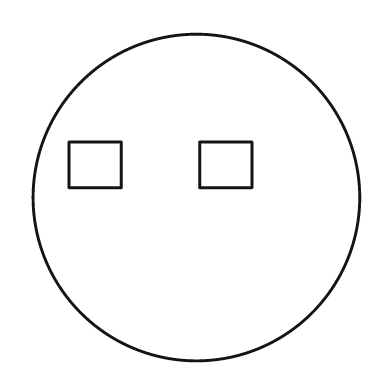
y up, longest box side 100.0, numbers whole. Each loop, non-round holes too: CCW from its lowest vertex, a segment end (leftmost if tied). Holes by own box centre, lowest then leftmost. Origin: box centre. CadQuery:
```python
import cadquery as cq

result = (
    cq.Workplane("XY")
    .moveTo(0.0, 0.0)
    .circle(50.0)
    .moveTo(-39.0, 3.0)
    .lineTo(-23.0, 3.0)
    .lineTo(-23.0, 17.0)
    .lineTo(-39.0, 17.0)
    .close()
    .moveTo(1.0, 3.0)
    .lineTo(17.0, 3.0)
    .lineTo(17.0, 17.0)
    .lineTo(1.0, 17.0)
    .close()
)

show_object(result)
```